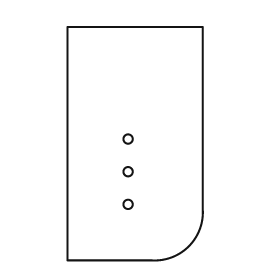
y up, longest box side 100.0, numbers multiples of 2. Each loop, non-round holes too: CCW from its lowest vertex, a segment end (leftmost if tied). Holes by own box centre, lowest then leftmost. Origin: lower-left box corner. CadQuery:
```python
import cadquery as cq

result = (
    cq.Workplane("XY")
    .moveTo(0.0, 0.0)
    .lineTo(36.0, 0.0)
    .threePointArc((52.0, 6.0), (58.0, 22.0))
    .lineTo(58.0, 100.0)
    .lineTo(0.0, 100.0)
    .close()
    .moveTo(26.0, 24.0)
    .circle(2.0)
    .moveTo(26.0, 38.0)
    .circle(2.0)
    .moveTo(26.0, 52.0)
    .circle(2.0)
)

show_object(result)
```